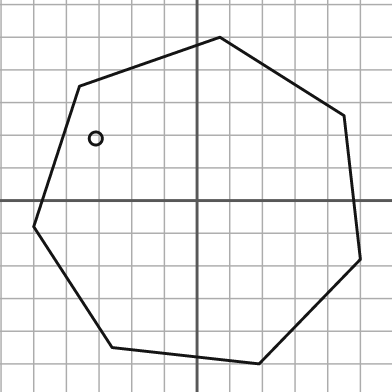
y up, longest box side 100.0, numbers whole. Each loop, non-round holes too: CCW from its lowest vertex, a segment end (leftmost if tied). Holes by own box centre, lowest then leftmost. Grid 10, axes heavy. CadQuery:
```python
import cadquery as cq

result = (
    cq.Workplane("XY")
    .moveTo(19.0, -50.0)
    .lineTo(50.0, -18.0)
    .lineTo(45.0, 26.0)
    .lineTo(7.0, 50.0)
    .lineTo(-36.0, 35.0)
    .lineTo(-50.0, -8.0)
    .lineTo(-26.0, -45.0)
    .close()
    .moveTo(-31.0, 19.0)
    .circle(2.0)
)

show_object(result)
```